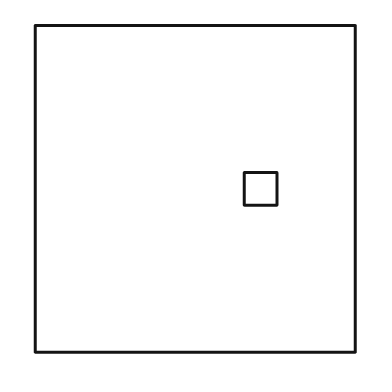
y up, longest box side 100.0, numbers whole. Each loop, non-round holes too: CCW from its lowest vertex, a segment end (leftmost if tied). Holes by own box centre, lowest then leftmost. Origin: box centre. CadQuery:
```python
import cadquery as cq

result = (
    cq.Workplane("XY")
    .moveTo(-49.0, -50.0)
    .lineTo(49.0, -50.0)
    .lineTo(49.0, 50.0)
    .lineTo(-49.0, 50.0)
    .close()
    .moveTo(15.0, -5.0)
    .lineTo(25.0, -5.0)
    .lineTo(25.0, 5.0)
    .lineTo(15.0, 5.0)
    .close()
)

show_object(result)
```